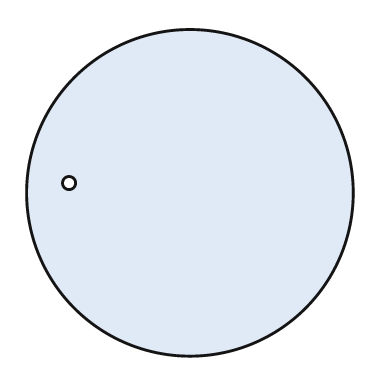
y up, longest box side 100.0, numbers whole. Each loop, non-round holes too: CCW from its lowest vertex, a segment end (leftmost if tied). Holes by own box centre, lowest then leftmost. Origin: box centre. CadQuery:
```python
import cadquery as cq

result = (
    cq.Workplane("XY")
    .moveTo(0.0, 0.0)
    .circle(50.0)
    .moveTo(-37.0, 3.0)
    .circle(2.0)
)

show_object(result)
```